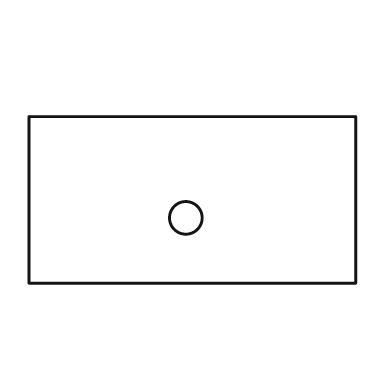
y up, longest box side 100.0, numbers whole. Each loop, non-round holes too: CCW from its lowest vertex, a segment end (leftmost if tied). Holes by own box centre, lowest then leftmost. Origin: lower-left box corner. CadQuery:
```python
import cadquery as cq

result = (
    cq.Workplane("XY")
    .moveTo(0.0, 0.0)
    .lineTo(100.0, 0.0)
    .lineTo(100.0, 51.0)
    .lineTo(0.0, 51.0)
    .close()
    .moveTo(48.0, 20.0)
    .circle(5.0)
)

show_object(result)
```